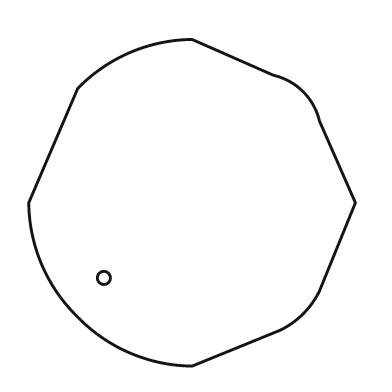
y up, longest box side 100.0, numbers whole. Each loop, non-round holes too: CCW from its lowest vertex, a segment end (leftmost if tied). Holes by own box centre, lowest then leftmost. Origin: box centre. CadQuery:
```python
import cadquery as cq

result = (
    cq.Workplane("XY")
    .moveTo(0.0, -50.0)
    .lineTo(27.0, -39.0)
    .threePointArc((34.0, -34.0), (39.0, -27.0))
    .lineTo(50.0, 0.0)
    .lineTo(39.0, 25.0)
    .threePointArc((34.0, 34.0), (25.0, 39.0))
    .lineTo(0.0, 50.0)
    .threePointArc((-19.0, 46.0), (-35.0, 35.0))
    .lineTo(-50.0, 0.0)
    .threePointArc((-46.0, -19.0), (-35.0, -35.0))
    .threePointArc((-19.0, -46.0), (0.0, -50.0))
    .close()
    .moveTo(-27.0, -23.0)
    .circle(2.0)
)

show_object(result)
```